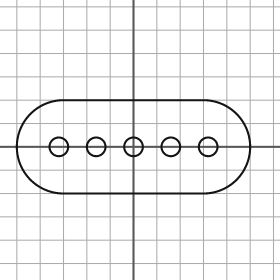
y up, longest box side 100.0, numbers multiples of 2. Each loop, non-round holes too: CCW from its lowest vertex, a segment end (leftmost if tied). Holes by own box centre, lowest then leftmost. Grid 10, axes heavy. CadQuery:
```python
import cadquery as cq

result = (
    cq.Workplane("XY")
    .moveTo(-30.0, -20.0)
    .lineTo(30.0, -20.0)
    .threePointArc((50.0, 0.0), (30.0, 20.0))
    .lineTo(-30.0, 20.0)
    .threePointArc((-50.0, 0.0), (-30.0, -20.0))
    .close()
    .moveTo(-32.0, 0.0)
    .circle(4.0)
    .moveTo(-16.0, 0.0)
    .circle(4.0)
    .moveTo(0.0, 0.0)
    .circle(4.0)
    .moveTo(16.0, 0.0)
    .circle(4.0)
    .moveTo(32.0, 0.0)
    .circle(4.0)
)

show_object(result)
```